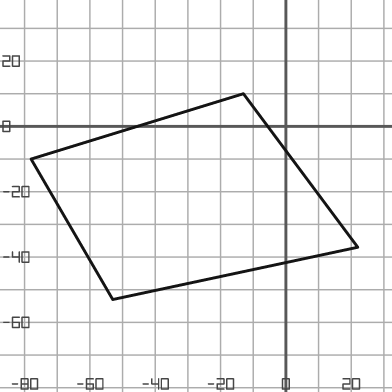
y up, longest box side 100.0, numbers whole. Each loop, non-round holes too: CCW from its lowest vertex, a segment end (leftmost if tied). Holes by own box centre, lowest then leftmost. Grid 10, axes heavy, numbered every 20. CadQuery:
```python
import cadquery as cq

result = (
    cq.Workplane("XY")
    .moveTo(-53.0, -53.0)
    .lineTo(22.0, -37.0)
    .lineTo(-13.0, 10.0)
    .lineTo(-78.0, -10.0)
    .close()
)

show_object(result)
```